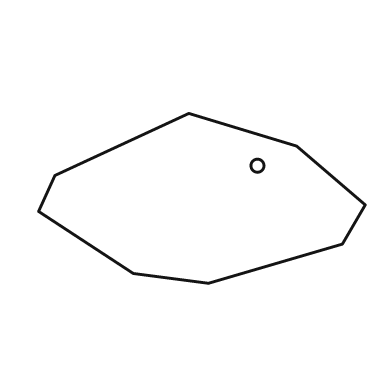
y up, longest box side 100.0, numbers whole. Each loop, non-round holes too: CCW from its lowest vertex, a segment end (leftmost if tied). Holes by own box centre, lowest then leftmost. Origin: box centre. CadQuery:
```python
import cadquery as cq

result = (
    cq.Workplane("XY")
    .moveTo(2.0, -26.0)
    .lineTo(43.0, -14.0)
    .lineTo(50.0, -2.0)
    .lineTo(29.0, 16.0)
    .lineTo(-4.0, 26.0)
    .lineTo(-45.0, 7.0)
    .lineTo(-50.0, -4.0)
    .lineTo(-21.0, -23.0)
    .close()
    .moveTo(17.0, 10.0)
    .circle(2.0)
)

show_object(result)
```